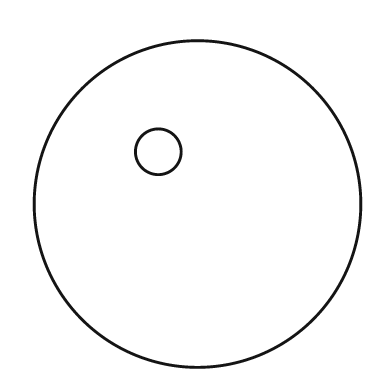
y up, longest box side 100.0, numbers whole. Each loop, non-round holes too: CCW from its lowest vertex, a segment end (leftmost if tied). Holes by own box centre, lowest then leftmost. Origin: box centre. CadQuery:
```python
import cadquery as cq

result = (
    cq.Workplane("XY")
    .moveTo(0.0, 0.0)
    .circle(50.0)
    .moveTo(-12.0, 16.0)
    .circle(7.0)
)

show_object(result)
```